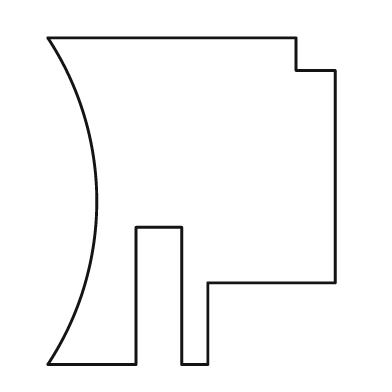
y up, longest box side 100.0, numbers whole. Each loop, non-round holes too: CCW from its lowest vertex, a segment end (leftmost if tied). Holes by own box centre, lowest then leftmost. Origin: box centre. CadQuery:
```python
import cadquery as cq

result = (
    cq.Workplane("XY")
    .moveTo(-44.0, -50.0)
    .lineTo(-17.0, -50.0)
    .lineTo(-17.0, -8.0)
    .lineTo(-3.0, -8.0)
    .lineTo(-3.0, -50.0)
    .lineTo(5.0, -50.0)
    .lineTo(5.0, -25.0)
    .lineTo(44.0, -25.0)
    .lineTo(44.0, 40.0)
    .lineTo(32.0, 40.0)
    .lineTo(32.0, 50.0)
    .lineTo(-44.0, 50.0)
    .threePointArc((-29.0, 0.0), (-44.0, -50.0))
    .close()
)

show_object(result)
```